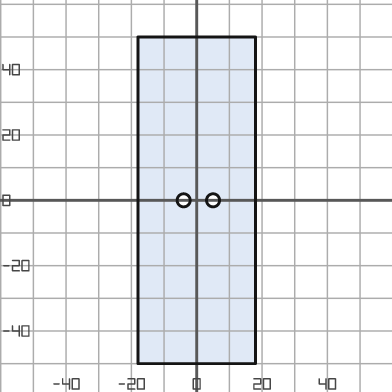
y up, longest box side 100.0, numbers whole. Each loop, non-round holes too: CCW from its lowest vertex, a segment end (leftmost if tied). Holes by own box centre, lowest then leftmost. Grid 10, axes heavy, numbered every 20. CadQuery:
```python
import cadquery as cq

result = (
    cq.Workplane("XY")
    .moveTo(-18.0, -50.0)
    .lineTo(18.0, -50.0)
    .lineTo(18.0, 50.0)
    .lineTo(-18.0, 50.0)
    .close()
    .moveTo(-4.0, 0.0)
    .circle(2.0)
    .moveTo(5.0, 0.0)
    .circle(2.0)
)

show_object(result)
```